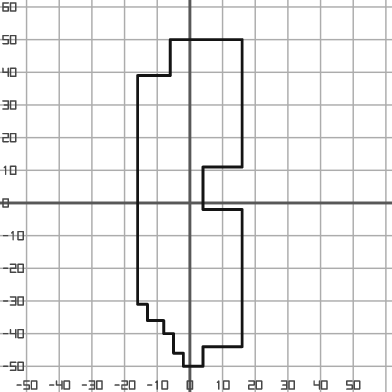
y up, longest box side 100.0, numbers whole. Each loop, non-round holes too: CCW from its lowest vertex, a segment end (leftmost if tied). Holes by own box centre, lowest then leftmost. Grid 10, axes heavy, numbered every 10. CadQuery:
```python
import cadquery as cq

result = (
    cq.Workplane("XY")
    .moveTo(-2.0, -50.0)
    .lineTo(4.0, -50.0)
    .lineTo(4.0, -44.0)
    .lineTo(16.0, -44.0)
    .lineTo(16.0, -2.0)
    .lineTo(4.0, -2.0)
    .lineTo(4.0, 11.0)
    .lineTo(16.0, 11.0)
    .lineTo(16.0, 50.0)
    .lineTo(-6.0, 50.0)
    .lineTo(-6.0, 39.0)
    .lineTo(-16.0, 39.0)
    .lineTo(-16.0, -31.0)
    .lineTo(-13.0, -31.0)
    .lineTo(-13.0, -36.0)
    .lineTo(-8.0, -36.0)
    .lineTo(-8.0, -40.0)
    .lineTo(-5.0, -40.0)
    .lineTo(-5.0, -46.0)
    .lineTo(-2.0, -46.0)
    .close()
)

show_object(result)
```